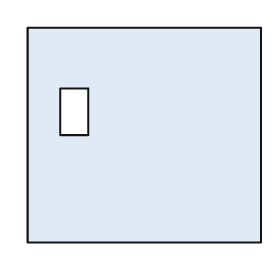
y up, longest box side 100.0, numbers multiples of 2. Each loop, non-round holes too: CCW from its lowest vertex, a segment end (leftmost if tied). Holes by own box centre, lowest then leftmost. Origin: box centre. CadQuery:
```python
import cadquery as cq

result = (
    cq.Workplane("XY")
    .moveTo(-50.0, -46.0)
    .lineTo(50.0, -46.0)
    .lineTo(50.0, 46.0)
    .lineTo(-50.0, 46.0)
    .close()
    .moveTo(-36.0, 0.0)
    .lineTo(-24.0, 0.0)
    .lineTo(-24.0, 20.0)
    .lineTo(-36.0, 20.0)
    .close()
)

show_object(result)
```